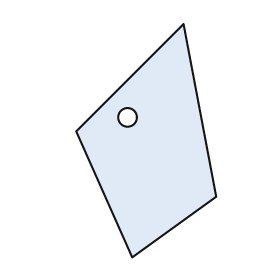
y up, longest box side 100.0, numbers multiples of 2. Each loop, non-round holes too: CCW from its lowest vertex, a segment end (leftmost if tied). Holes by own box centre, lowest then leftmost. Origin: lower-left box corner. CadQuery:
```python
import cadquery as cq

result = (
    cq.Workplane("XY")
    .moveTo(24.0, 0.0)
    .lineTo(60.0, 26.0)
    .lineTo(46.0, 100.0)
    .lineTo(0.0, 54.0)
    .close()
    .moveTo(22.0, 60.0)
    .circle(4.0)
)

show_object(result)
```